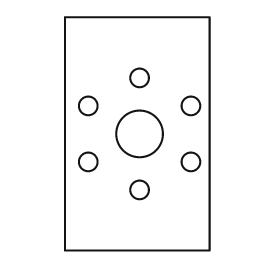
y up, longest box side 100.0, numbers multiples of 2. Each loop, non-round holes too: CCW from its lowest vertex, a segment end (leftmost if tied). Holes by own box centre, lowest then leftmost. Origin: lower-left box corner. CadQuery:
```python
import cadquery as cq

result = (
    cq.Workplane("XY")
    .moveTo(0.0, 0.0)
    .lineTo(62.0, 0.0)
    .lineTo(62.0, 100.0)
    .lineTo(0.0, 100.0)
    .close()
    .moveTo(32.0, 26.0)
    .circle(4.0)
    .moveTo(10.0, 38.0)
    .circle(4.0)
    .moveTo(54.0, 38.0)
    .circle(4.0)
    .moveTo(32.0, 50.0)
    .circle(10.0)
    .moveTo(10.0, 62.0)
    .circle(4.0)
    .moveTo(54.0, 62.0)
    .circle(4.0)
    .moveTo(32.0, 74.0)
    .circle(4.0)
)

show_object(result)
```